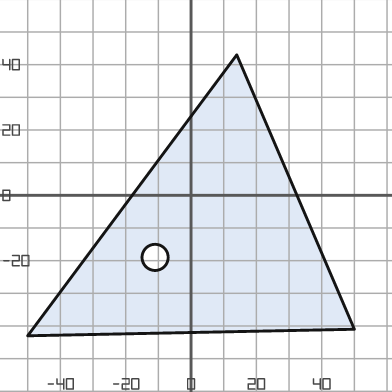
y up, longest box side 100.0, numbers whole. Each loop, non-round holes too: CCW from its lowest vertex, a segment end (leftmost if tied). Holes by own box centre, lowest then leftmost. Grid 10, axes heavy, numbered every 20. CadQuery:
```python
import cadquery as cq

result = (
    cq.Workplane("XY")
    .moveTo(-50.0, -43.0)
    .lineTo(50.0, -41.0)
    .lineTo(14.0, 43.0)
    .close()
    .moveTo(-11.0, -19.0)
    .circle(4.0)
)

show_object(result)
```